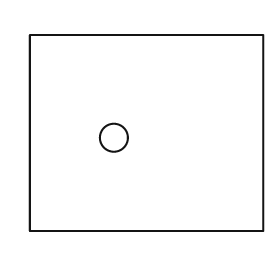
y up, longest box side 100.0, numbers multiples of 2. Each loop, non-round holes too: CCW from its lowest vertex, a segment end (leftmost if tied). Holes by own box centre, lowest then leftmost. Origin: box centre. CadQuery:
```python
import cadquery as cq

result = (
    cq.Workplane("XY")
    .moveTo(-50.0, -42.0)
    .lineTo(50.0, -42.0)
    .lineTo(50.0, 42.0)
    .lineTo(-50.0, 42.0)
    .close()
    .moveTo(-14.0, -2.0)
    .circle(6.0)
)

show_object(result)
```